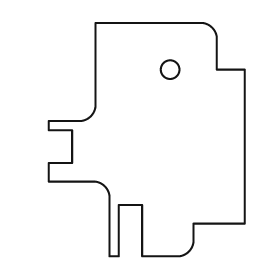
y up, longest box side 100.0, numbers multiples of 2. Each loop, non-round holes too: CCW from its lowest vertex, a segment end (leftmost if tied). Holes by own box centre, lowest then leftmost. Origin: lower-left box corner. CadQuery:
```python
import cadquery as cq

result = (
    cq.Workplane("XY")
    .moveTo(26.0, 0.0)
    .lineTo(30.0, 0.0)
    .lineTo(30.0, 22.0)
    .lineTo(40.0, 22.0)
    .lineTo(40.0, 0.0)
    .lineTo(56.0, 0.0)
    .threePointArc((60.0, 2.0), (62.0, 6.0))
    .lineTo(62.0, 14.0)
    .lineTo(84.0, 14.0)
    .lineTo(84.0, 80.0)
    .lineTo(72.0, 80.0)
    .lineTo(72.0, 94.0)
    .threePointArc((70.0, 98.0), (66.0, 100.0))
    .lineTo(20.0, 100.0)
    .lineTo(20.0, 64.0)
    .threePointArc((18.0, 60.0), (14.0, 58.0))
    .lineTo(0.0, 58.0)
    .lineTo(0.0, 54.0)
    .lineTo(10.0, 54.0)
    .lineTo(10.0, 40.0)
    .lineTo(0.0, 40.0)
    .lineTo(0.0, 32.0)
    .lineTo(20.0, 32.0)
    .threePointArc((24.0, 30.0), (26.0, 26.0))
    .close()
    .moveTo(52.0, 80.0)
    .circle(4.0)
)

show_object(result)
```